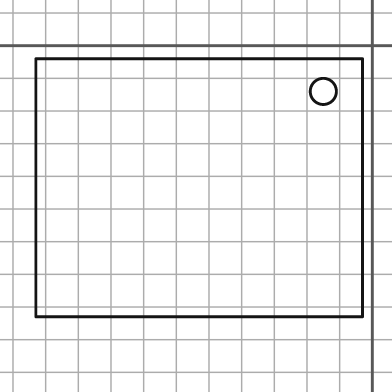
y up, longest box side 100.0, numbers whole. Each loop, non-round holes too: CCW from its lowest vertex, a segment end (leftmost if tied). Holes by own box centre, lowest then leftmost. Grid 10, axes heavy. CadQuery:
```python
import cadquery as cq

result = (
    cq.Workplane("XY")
    .moveTo(-103.0, -83.0)
    .lineTo(-3.0, -83.0)
    .lineTo(-3.0, -4.0)
    .lineTo(-103.0, -4.0)
    .close()
    .moveTo(-15.0, -14.0)
    .circle(4.0)
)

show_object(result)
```